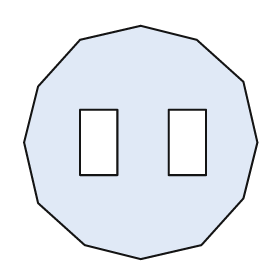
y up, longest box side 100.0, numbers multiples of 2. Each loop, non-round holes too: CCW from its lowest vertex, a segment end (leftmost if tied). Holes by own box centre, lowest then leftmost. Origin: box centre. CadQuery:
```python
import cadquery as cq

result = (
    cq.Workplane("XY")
    .moveTo(0.0, -50.0)
    .lineTo(26.0, -44.0)
    .lineTo(44.0, -24.0)
    .lineTo(50.0, 0.0)
    .lineTo(44.0, 26.0)
    .lineTo(24.0, 44.0)
    .lineTo(0.0, 50.0)
    .lineTo(-26.0, 44.0)
    .lineTo(-44.0, 24.0)
    .lineTo(-50.0, 0.0)
    .lineTo(-44.0, -26.0)
    .lineTo(-24.0, -44.0)
    .close()
    .moveTo(-26.0, -14.0)
    .lineTo(-10.0, -14.0)
    .lineTo(-10.0, 14.0)
    .lineTo(-26.0, 14.0)
    .close()
    .moveTo(12.0, -14.0)
    .lineTo(28.0, -14.0)
    .lineTo(28.0, 14.0)
    .lineTo(12.0, 14.0)
    .close()
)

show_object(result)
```